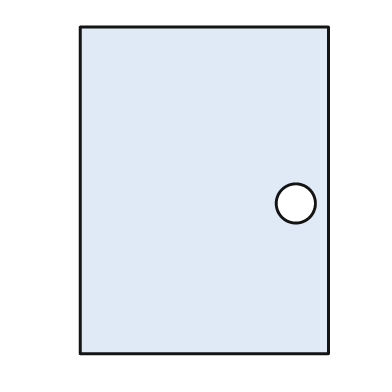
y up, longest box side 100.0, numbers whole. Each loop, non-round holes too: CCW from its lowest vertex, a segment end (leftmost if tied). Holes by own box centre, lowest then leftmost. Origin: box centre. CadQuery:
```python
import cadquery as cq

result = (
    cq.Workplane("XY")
    .moveTo(-38.0, -50.0)
    .lineTo(38.0, -50.0)
    .lineTo(38.0, 50.0)
    .lineTo(-38.0, 50.0)
    .close()
    .moveTo(28.0, -4.0)
    .circle(6.0)
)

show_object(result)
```